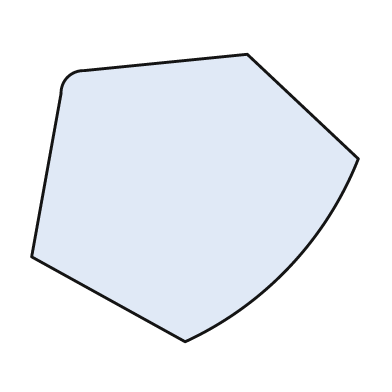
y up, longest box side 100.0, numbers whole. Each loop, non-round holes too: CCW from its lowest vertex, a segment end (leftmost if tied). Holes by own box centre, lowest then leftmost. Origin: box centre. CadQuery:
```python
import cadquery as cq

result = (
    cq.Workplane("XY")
    .moveTo(-3.0, -44.0)
    .threePointArc((29.0, -21.0), (50.0, 12.0))
    .lineTo(16.0, 44.0)
    .lineTo(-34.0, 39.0)
    .threePointArc((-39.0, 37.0), (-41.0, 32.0))
    .lineTo(-50.0, -18.0)
    .close()
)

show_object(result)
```